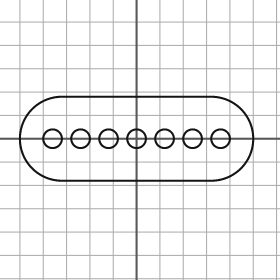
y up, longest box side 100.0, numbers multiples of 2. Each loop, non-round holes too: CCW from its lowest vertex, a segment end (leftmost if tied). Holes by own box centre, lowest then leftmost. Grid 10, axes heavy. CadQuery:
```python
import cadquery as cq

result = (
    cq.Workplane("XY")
    .moveTo(-32.0, -18.0)
    .lineTo(32.0, -18.0)
    .threePointArc((50.0, 0.0), (32.0, 18.0))
    .lineTo(-32.0, 18.0)
    .threePointArc((-50.0, 0.0), (-32.0, -18.0))
    .close()
    .moveTo(-36.0, 0.0)
    .circle(4.0)
    .moveTo(-24.0, 0.0)
    .circle(4.0)
    .moveTo(-12.0, 0.0)
    .circle(4.0)
    .moveTo(0.0, 0.0)
    .circle(4.0)
    .moveTo(12.0, 0.0)
    .circle(4.0)
    .moveTo(24.0, 0.0)
    .circle(4.0)
    .moveTo(36.0, 0.0)
    .circle(4.0)
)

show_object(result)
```